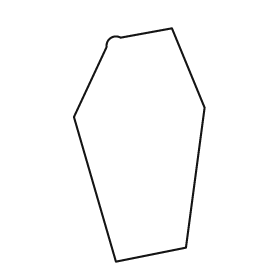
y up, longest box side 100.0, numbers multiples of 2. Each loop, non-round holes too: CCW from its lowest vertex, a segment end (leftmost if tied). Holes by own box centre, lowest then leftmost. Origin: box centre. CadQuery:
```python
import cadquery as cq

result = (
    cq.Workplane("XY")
    .moveTo(-10.0, -50.0)
    .lineTo(20.0, -44.0)
    .lineTo(28.0, 16.0)
    .lineTo(14.0, 50.0)
    .lineTo(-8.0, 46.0)
    .threePointArc((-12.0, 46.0), (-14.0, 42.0))
    .lineTo(-28.0, 12.0)
    .close()
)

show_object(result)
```